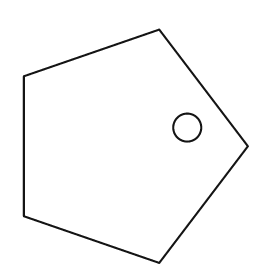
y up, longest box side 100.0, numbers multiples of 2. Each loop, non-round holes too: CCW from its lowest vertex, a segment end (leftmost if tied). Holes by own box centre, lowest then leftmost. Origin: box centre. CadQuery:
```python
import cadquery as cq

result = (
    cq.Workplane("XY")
    .moveTo(10.0, -50.0)
    .lineTo(48.0, 0.0)
    .lineTo(10.0, 50.0)
    .lineTo(-48.0, 30.0)
    .lineTo(-48.0, -30.0)
    .close()
    .moveTo(22.0, 8.0)
    .circle(6.0)
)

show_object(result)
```